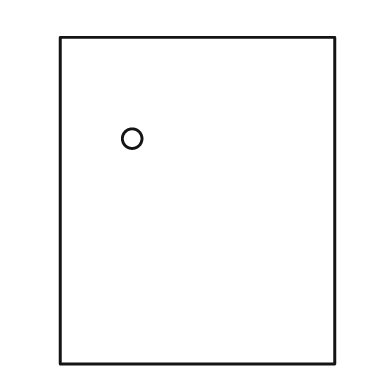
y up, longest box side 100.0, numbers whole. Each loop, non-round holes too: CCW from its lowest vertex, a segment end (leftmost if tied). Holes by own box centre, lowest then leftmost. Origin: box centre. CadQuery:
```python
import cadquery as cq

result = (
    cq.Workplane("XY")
    .moveTo(-42.0, -50.0)
    .lineTo(42.0, -50.0)
    .lineTo(42.0, 50.0)
    .lineTo(-42.0, 50.0)
    .close()
    .moveTo(-20.0, 19.0)
    .circle(3.0)
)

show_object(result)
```